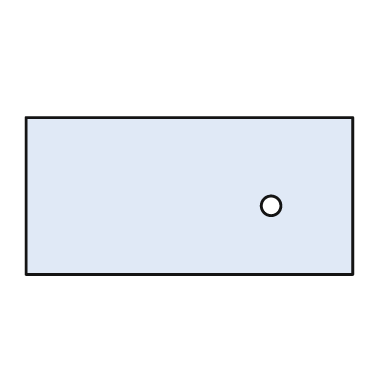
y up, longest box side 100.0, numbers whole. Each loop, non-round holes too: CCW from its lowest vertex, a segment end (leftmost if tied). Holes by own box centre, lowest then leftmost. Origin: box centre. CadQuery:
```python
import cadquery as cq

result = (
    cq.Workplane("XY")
    .moveTo(-50.0, -24.0)
    .lineTo(50.0, -24.0)
    .lineTo(50.0, 24.0)
    .lineTo(-50.0, 24.0)
    .close()
    .moveTo(25.0, -3.0)
    .circle(3.0)
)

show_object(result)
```